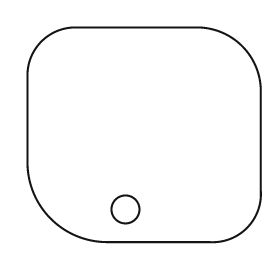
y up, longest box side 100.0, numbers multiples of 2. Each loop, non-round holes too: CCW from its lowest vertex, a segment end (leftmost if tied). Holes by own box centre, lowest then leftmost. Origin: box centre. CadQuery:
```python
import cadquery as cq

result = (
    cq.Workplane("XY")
    .moveTo(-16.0, -46.0)
    .lineTo(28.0, -46.0)
    .threePointArc((44.0, -40.0), (50.0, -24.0))
    .lineTo(50.0, 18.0)
    .threePointArc((42.0, 38.0), (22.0, 46.0))
    .lineTo(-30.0, 46.0)
    .threePointArc((-44.0, 40.0), (-50.0, 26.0))
    .lineTo(-50.0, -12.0)
    .threePointArc((-40.0, -36.0), (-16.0, -46.0))
    .close()
    .moveTo(-8.0, -32.0)
    .circle(6.0)
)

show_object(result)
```